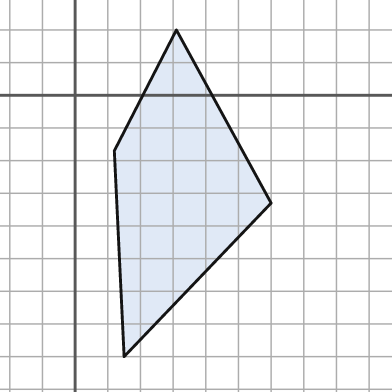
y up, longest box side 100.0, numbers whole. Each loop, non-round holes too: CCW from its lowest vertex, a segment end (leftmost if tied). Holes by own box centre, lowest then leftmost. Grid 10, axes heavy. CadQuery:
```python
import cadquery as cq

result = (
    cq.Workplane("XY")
    .moveTo(15.0, -80.0)
    .lineTo(60.0, -33.0)
    .lineTo(31.0, 20.0)
    .lineTo(12.0, -17.0)
    .close()
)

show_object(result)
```